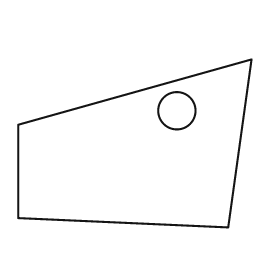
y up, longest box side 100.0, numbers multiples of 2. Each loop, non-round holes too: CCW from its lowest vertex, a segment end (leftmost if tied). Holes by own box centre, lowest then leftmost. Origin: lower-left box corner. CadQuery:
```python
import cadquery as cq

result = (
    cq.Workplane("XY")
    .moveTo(90.0, 0.0)
    .lineTo(100.0, 72.0)
    .lineTo(0.0, 44.0)
    .lineTo(0.0, 4.0)
    .close()
    .moveTo(68.0, 50.0)
    .circle(8.0)
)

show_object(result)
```